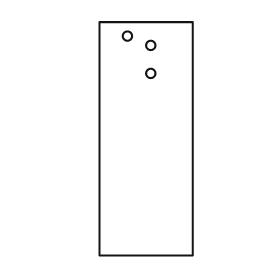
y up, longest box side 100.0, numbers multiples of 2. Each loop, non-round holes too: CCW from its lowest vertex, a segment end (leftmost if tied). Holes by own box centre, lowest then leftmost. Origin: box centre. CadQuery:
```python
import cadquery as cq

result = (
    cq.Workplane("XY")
    .moveTo(-20.0, -50.0)
    .lineTo(20.0, -50.0)
    .lineTo(20.0, 50.0)
    .lineTo(-20.0, 50.0)
    .close()
    .moveTo(2.0, 28.0)
    .circle(2.0)
    .moveTo(2.0, 40.0)
    .circle(2.0)
    .moveTo(-8.0, 44.0)
    .circle(2.0)
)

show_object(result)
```